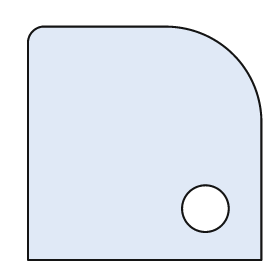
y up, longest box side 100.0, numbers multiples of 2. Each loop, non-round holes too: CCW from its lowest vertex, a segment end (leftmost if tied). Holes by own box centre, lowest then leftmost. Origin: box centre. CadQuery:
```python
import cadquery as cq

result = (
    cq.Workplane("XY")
    .moveTo(-50.0, -50.0)
    .lineTo(50.0, -50.0)
    .lineTo(50.0, 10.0)
    .threePointArc((38.0, 38.0), (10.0, 50.0))
    .lineTo(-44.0, 50.0)
    .threePointArc((-48.0, 48.0), (-50.0, 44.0))
    .close()
    .moveTo(26.0, -28.0)
    .circle(10.0)
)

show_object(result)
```